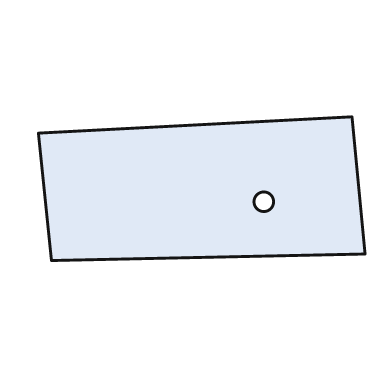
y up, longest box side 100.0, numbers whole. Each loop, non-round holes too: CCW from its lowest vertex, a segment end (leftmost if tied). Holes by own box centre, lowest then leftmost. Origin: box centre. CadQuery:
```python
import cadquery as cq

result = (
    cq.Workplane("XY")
    .moveTo(-46.0, -22.0)
    .lineTo(50.0, -20.0)
    .lineTo(46.0, 22.0)
    .lineTo(-50.0, 17.0)
    .close()
    .moveTo(19.0, -4.0)
    .circle(3.0)
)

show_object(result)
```